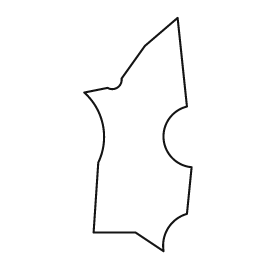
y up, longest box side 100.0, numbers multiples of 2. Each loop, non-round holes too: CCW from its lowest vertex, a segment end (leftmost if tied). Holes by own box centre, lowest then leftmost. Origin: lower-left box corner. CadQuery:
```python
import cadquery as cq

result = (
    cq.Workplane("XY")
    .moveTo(34.0, 0.0)
    .threePointArc((36.0, 10.0), (44.0, 16.0))
    .lineTo(46.0, 36.0)
    .threePointArc((34.0, 48.0), (44.0, 62.0))
    .lineTo(40.0, 100.0)
    .lineTo(26.0, 88.0)
    .lineTo(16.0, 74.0)
    .threePointArc((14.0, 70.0), (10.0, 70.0))
    .lineTo(0.0, 68.0)
    .threePointArc((8.0, 54.0), (6.0, 38.0))
    .lineTo(4.0, 8.0)
    .lineTo(22.0, 8.0)
    .close()
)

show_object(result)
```